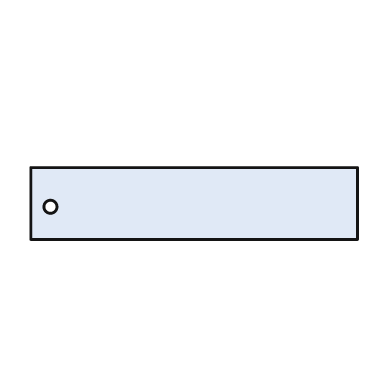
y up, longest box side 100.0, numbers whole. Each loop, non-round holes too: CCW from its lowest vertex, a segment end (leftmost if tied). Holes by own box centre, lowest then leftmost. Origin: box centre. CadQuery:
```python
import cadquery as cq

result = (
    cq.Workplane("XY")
    .moveTo(-50.0, -11.0)
    .lineTo(50.0, -11.0)
    .lineTo(50.0, 11.0)
    .lineTo(-50.0, 11.0)
    .close()
    .moveTo(-44.0, -1.0)
    .circle(2.0)
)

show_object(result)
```